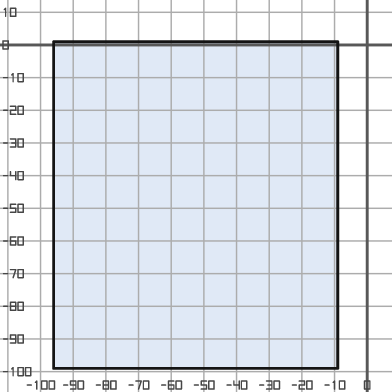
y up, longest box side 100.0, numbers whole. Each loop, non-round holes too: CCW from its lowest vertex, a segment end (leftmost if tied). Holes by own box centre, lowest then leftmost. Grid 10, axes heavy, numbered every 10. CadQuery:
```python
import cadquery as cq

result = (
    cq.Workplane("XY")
    .moveTo(-96.0, -99.0)
    .lineTo(-9.0, -99.0)
    .lineTo(-9.0, 1.0)
    .lineTo(-96.0, 1.0)
    .close()
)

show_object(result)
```